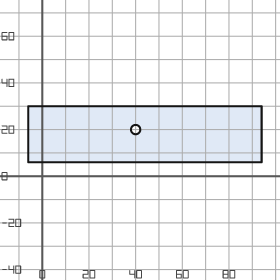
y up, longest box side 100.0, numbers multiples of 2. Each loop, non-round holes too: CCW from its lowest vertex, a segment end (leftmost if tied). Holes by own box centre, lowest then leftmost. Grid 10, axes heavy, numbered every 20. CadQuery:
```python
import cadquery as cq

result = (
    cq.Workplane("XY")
    .moveTo(-6.0, 6.0)
    .lineTo(94.0, 6.0)
    .lineTo(94.0, 30.0)
    .lineTo(-6.0, 30.0)
    .close()
    .moveTo(40.0, 20.0)
    .circle(2.0)
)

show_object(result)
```